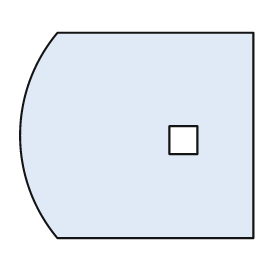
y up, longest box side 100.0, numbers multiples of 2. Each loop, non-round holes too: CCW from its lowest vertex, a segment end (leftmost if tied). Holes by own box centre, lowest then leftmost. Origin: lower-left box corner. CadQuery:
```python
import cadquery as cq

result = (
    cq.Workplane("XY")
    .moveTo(16.0, 0.0)
    .lineTo(100.0, 0.0)
    .lineTo(100.0, 88.0)
    .lineTo(16.0, 88.0)
    .threePointArc((0.0, 44.0), (16.0, 0.0))
    .close()
    .moveTo(64.0, 36.0)
    .lineTo(76.0, 36.0)
    .lineTo(76.0, 48.0)
    .lineTo(64.0, 48.0)
    .close()
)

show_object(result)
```